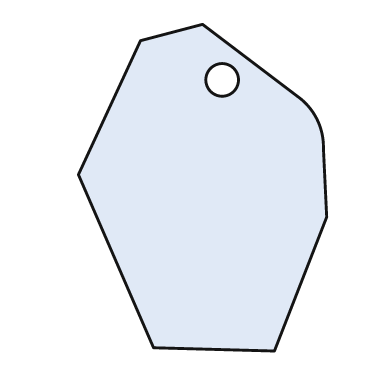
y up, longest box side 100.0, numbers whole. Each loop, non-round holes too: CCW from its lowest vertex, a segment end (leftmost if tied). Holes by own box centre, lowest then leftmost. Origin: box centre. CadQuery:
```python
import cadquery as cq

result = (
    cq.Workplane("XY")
    .moveTo(22.0, -50.0)
    .lineTo(38.0, -9.0)
    .lineTo(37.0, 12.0)
    .threePointArc((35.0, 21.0), (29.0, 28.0))
    .lineTo(0.0, 50.0)
    .lineTo(-19.0, 45.0)
    .lineTo(-38.0, 4.0)
    .lineTo(-15.0, -49.0)
    .close()
    .moveTo(6.0, 33.0)
    .circle(5.0)
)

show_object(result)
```